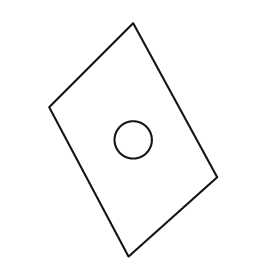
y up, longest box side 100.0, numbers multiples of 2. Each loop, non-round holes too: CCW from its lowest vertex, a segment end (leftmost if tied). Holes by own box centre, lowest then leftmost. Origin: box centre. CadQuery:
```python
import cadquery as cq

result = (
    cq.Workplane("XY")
    .moveTo(-2.0, -50.0)
    .lineTo(36.0, -16.0)
    .lineTo(0.0, 50.0)
    .lineTo(-36.0, 14.0)
    .close()
    .moveTo(0.0, 0.0)
    .circle(8.0)
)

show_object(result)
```